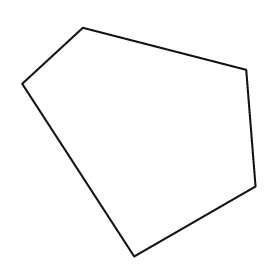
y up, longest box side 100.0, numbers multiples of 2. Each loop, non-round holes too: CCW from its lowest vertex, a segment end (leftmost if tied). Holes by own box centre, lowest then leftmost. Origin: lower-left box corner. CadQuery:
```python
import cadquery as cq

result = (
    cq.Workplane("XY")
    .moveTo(48.0, 0.0)
    .lineTo(100.0, 30.0)
    .lineTo(96.0, 80.0)
    .lineTo(26.0, 98.0)
    .lineTo(0.0, 74.0)
    .close()
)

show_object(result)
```